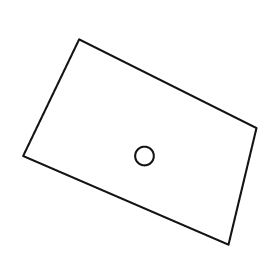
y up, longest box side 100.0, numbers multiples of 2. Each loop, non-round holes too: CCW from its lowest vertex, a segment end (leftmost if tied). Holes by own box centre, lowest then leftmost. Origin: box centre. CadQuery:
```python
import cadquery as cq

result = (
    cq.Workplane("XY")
    .moveTo(38.0, -44.0)
    .lineTo(50.0, 6.0)
    .lineTo(-26.0, 44.0)
    .lineTo(-50.0, -6.0)
    .close()
    .moveTo(2.0, -6.0)
    .circle(4.0)
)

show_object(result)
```